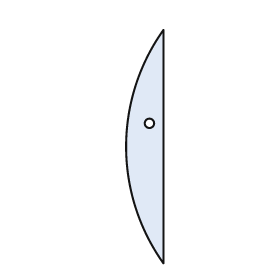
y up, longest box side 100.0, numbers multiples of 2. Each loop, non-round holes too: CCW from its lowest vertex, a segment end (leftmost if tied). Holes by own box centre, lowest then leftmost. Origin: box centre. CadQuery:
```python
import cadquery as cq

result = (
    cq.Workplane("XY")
    .moveTo(8.0, -50.0)
    .lineTo(8.0, 50.0)
    .threePointArc((-8.0, 0.0), (8.0, -50.0))
    .close()
    .moveTo(2.0, 10.0)
    .circle(2.0)
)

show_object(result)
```